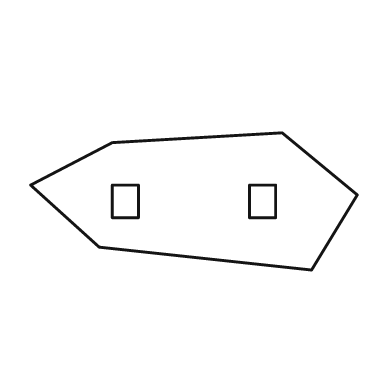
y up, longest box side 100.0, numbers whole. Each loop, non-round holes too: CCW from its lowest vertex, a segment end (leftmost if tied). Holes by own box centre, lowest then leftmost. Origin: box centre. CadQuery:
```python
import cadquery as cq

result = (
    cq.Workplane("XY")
    .moveTo(36.0, -21.0)
    .lineTo(50.0, 2.0)
    .lineTo(27.0, 21.0)
    .lineTo(-25.0, 18.0)
    .lineTo(-50.0, 5.0)
    .lineTo(-29.0, -14.0)
    .close()
    .moveTo(-25.0, -5.0)
    .lineTo(-17.0, -5.0)
    .lineTo(-17.0, 5.0)
    .lineTo(-25.0, 5.0)
    .close()
    .moveTo(17.0, -5.0)
    .lineTo(25.0, -5.0)
    .lineTo(25.0, 5.0)
    .lineTo(17.0, 5.0)
    .close()
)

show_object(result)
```